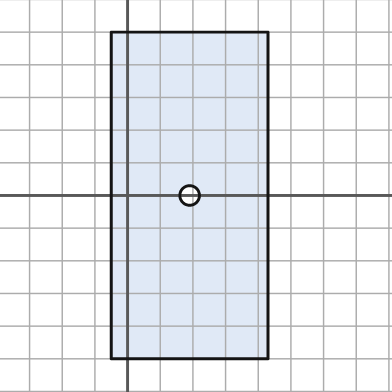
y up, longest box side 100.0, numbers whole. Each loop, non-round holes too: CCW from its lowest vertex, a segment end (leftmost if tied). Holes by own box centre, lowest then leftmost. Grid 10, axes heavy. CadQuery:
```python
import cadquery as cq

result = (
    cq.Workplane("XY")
    .moveTo(-5.0, -50.0)
    .lineTo(43.0, -50.0)
    .lineTo(43.0, 50.0)
    .lineTo(-5.0, 50.0)
    .close()
    .moveTo(19.0, 0.0)
    .circle(3.0)
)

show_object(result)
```